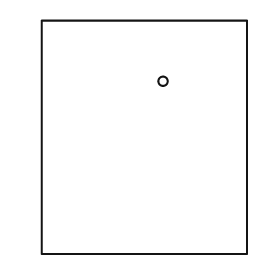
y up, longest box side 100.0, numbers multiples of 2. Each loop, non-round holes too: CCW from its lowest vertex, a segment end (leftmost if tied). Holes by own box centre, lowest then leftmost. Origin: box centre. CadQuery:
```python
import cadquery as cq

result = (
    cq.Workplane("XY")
    .moveTo(-44.0, -50.0)
    .lineTo(44.0, -50.0)
    .lineTo(44.0, 50.0)
    .lineTo(-44.0, 50.0)
    .close()
    .moveTo(8.0, 24.0)
    .circle(2.0)
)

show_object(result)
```